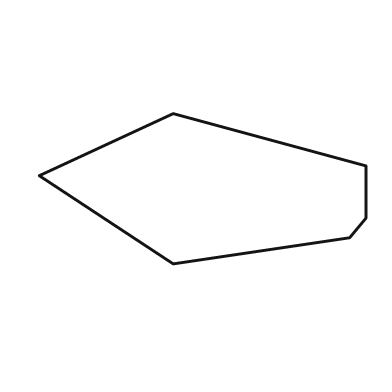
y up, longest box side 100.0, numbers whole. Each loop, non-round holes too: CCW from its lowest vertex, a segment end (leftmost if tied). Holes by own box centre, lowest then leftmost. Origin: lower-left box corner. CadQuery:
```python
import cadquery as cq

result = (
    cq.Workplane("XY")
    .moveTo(41.0, 0.0)
    .lineTo(95.0, 8.0)
    .lineTo(100.0, 14.0)
    .lineTo(100.0, 30.0)
    .lineTo(41.0, 46.0)
    .lineTo(0.0, 27.0)
    .close()
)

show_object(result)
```